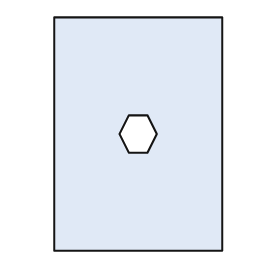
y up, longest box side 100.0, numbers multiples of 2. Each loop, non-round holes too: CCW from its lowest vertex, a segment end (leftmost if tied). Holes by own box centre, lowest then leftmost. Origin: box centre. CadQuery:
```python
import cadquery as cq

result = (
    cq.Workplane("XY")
    .moveTo(-36.0, -50.0)
    .lineTo(36.0, -50.0)
    .lineTo(36.0, 50.0)
    .lineTo(-36.0, 50.0)
    .close()
    .moveTo(-4.0, -8.0)
    .lineTo(4.0, -8.0)
    .lineTo(8.0, 0.0)
    .lineTo(4.0, 8.0)
    .lineTo(-4.0, 8.0)
    .lineTo(-8.0, 0.0)
    .close()
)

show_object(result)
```